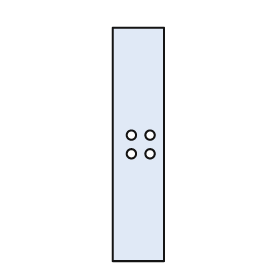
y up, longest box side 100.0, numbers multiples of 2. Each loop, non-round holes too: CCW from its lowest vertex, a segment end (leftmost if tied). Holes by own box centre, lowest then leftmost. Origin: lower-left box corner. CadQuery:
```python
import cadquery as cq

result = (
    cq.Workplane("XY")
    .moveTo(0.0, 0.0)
    .lineTo(22.0, 0.0)
    .lineTo(22.0, 100.0)
    .lineTo(0.0, 100.0)
    .close()
    .moveTo(8.0, 46.0)
    .circle(2.0)
    .moveTo(16.0, 46.0)
    .circle(2.0)
    .moveTo(8.0, 54.0)
    .circle(2.0)
    .moveTo(16.0, 54.0)
    .circle(2.0)
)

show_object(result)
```